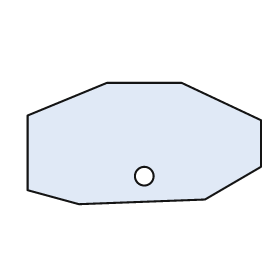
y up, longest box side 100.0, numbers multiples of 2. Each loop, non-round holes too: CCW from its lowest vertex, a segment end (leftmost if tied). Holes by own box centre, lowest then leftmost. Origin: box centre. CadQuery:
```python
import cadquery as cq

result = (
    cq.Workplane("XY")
    .moveTo(-28.0, -26.0)
    .lineTo(26.0, -24.0)
    .lineTo(50.0, -10.0)
    .lineTo(50.0, 10.0)
    .lineTo(16.0, 26.0)
    .lineTo(-16.0, 26.0)
    .lineTo(-50.0, 12.0)
    .lineTo(-50.0, -20.0)
    .close()
    .moveTo(0.0, -14.0)
    .circle(4.0)
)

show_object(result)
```